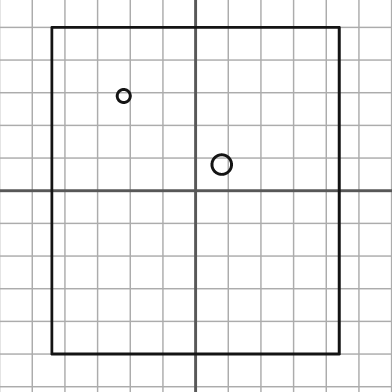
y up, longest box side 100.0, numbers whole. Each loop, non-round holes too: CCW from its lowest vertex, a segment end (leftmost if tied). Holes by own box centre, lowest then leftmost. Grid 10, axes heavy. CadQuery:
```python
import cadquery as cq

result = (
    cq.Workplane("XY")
    .moveTo(-44.0, -50.0)
    .lineTo(44.0, -50.0)
    .lineTo(44.0, 50.0)
    .lineTo(-44.0, 50.0)
    .close()
    .moveTo(8.0, 8.0)
    .circle(3.0)
    .moveTo(-22.0, 29.0)
    .circle(2.0)
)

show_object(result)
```